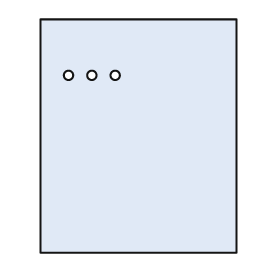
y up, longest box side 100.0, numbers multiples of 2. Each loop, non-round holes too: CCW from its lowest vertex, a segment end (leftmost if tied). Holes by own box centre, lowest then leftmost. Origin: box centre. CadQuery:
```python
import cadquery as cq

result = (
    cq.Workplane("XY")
    .moveTo(-42.0, -50.0)
    .lineTo(42.0, -50.0)
    .lineTo(42.0, 50.0)
    .lineTo(-42.0, 50.0)
    .close()
    .moveTo(-30.0, 26.0)
    .circle(2.0)
    .moveTo(-20.0, 26.0)
    .circle(2.0)
    .moveTo(-10.0, 26.0)
    .circle(2.0)
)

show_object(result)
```